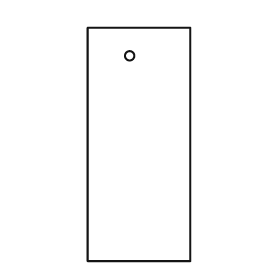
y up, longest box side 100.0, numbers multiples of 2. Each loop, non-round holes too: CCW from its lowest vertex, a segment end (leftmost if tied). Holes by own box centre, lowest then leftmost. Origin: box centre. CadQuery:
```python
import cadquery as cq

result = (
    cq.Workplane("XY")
    .moveTo(-22.0, -50.0)
    .lineTo(22.0, -50.0)
    .lineTo(22.0, 50.0)
    .lineTo(-22.0, 50.0)
    .close()
    .moveTo(-4.0, 38.0)
    .circle(2.0)
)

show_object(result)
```